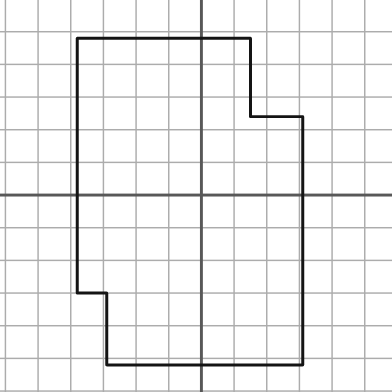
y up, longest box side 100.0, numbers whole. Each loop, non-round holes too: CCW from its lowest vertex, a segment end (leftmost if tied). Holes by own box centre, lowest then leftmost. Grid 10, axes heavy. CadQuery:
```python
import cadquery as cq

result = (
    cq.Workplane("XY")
    .moveTo(-29.0, -52.0)
    .lineTo(31.0, -52.0)
    .lineTo(31.0, 24.0)
    .lineTo(15.0, 24.0)
    .lineTo(15.0, 48.0)
    .lineTo(-38.0, 48.0)
    .lineTo(-38.0, -30.0)
    .lineTo(-29.0, -30.0)
    .close()
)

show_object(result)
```